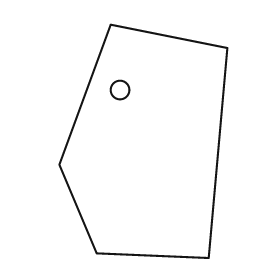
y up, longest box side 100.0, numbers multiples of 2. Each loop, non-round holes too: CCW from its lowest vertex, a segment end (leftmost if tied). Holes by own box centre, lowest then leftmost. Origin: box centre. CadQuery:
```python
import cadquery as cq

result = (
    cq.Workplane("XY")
    .moveTo(28.0, -50.0)
    .lineTo(36.0, 40.0)
    .lineTo(-14.0, 50.0)
    .lineTo(-36.0, -10.0)
    .lineTo(-20.0, -48.0)
    .close()
    .moveTo(-10.0, 22.0)
    .circle(4.0)
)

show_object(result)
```